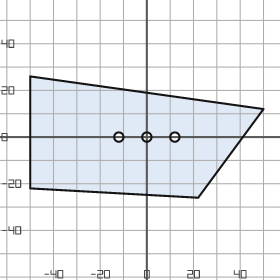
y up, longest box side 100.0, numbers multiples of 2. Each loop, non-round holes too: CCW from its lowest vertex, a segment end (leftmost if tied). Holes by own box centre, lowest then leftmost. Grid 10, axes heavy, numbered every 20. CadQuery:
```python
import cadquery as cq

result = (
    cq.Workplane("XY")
    .moveTo(22.0, -26.0)
    .lineTo(50.0, 12.0)
    .lineTo(-50.0, 26.0)
    .lineTo(-50.0, -22.0)
    .close()
    .moveTo(-12.0, 0.0)
    .circle(2.0)
    .moveTo(0.0, 0.0)
    .circle(2.0)
    .moveTo(12.0, 0.0)
    .circle(2.0)
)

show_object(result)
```